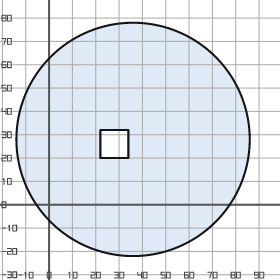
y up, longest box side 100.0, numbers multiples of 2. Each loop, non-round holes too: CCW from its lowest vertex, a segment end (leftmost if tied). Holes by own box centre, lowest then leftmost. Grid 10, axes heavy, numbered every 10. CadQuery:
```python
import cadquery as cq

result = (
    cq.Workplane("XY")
    .moveTo(36.0, 28.0)
    .circle(50.0)
    .moveTo(22.0, 20.0)
    .lineTo(34.0, 20.0)
    .lineTo(34.0, 32.0)
    .lineTo(22.0, 32.0)
    .close()
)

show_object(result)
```